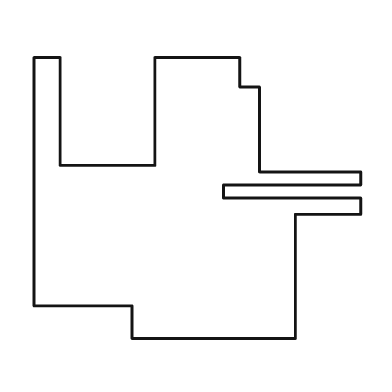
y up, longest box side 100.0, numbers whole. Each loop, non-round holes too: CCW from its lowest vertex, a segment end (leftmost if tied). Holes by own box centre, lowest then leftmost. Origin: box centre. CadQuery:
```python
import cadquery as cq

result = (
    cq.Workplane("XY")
    .moveTo(-20.0, -43.0)
    .lineTo(30.0, -43.0)
    .lineTo(30.0, -5.0)
    .lineTo(50.0, -5.0)
    .lineTo(50.0, 0.0)
    .lineTo(8.0, 0.0)
    .lineTo(8.0, 4.0)
    .lineTo(50.0, 4.0)
    .lineTo(50.0, 8.0)
    .lineTo(19.0, 8.0)
    .lineTo(19.0, 34.0)
    .lineTo(13.0, 34.0)
    .lineTo(13.0, 43.0)
    .lineTo(-13.0, 43.0)
    .lineTo(-13.0, 10.0)
    .lineTo(-42.0, 10.0)
    .lineTo(-42.0, 43.0)
    .lineTo(-50.0, 43.0)
    .lineTo(-50.0, -33.0)
    .lineTo(-20.0, -33.0)
    .close()
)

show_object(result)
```